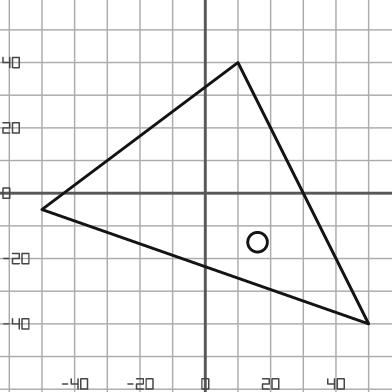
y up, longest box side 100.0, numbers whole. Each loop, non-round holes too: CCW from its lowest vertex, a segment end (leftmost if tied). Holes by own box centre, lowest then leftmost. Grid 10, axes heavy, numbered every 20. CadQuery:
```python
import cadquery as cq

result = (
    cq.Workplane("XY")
    .moveTo(50.0, -40.0)
    .lineTo(10.0, 40.0)
    .lineTo(-50.0, -5.0)
    .close()
    .moveTo(16.0, -15.0)
    .circle(3.0)
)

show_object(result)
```